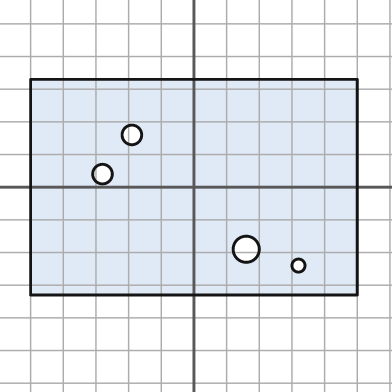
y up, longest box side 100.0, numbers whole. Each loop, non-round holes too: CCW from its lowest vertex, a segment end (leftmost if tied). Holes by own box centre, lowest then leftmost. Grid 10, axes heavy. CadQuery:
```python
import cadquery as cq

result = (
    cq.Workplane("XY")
    .moveTo(-50.0, -33.0)
    .lineTo(50.0, -33.0)
    .lineTo(50.0, 33.0)
    .lineTo(-50.0, 33.0)
    .close()
    .moveTo(32.0, -24.0)
    .circle(2.0)
    .moveTo(16.0, -19.0)
    .circle(4.0)
    .moveTo(-28.0, 4.0)
    .circle(3.0)
    .moveTo(-19.0, 16.0)
    .circle(3.0)
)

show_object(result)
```